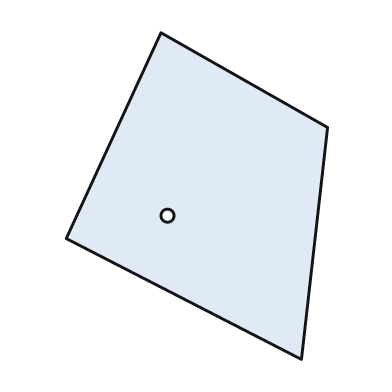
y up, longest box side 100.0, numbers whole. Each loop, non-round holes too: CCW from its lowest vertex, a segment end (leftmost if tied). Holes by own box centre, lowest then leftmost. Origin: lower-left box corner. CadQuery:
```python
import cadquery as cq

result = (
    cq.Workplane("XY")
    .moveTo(72.0, 0.0)
    .lineTo(80.0, 71.0)
    .lineTo(29.0, 100.0)
    .lineTo(0.0, 37.0)
    .close()
    .moveTo(31.0, 44.0)
    .circle(2.0)
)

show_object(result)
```